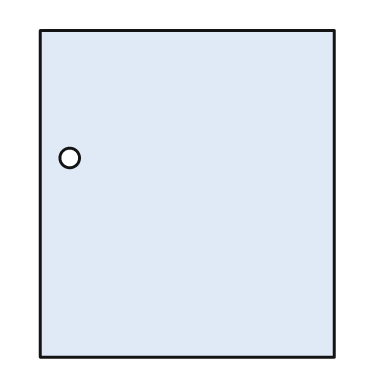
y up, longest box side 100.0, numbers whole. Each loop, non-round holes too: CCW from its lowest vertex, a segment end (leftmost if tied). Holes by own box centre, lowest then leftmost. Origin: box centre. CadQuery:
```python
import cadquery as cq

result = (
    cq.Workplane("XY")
    .moveTo(-45.0, -50.0)
    .lineTo(45.0, -50.0)
    .lineTo(45.0, 50.0)
    .lineTo(-45.0, 50.0)
    .close()
    .moveTo(-36.0, 11.0)
    .circle(3.0)
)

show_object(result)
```